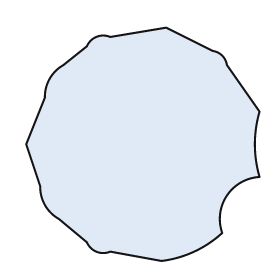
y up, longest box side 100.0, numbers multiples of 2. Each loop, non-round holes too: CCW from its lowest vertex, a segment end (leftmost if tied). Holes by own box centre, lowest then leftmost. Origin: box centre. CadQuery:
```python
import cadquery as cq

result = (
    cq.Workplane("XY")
    .moveTo(8.0, -50.0)
    .threePointArc((22.0, -46.0), (34.0, -38.0))
    .threePointArc((36.0, -22.0), (50.0, -14.0))
    .threePointArc((48.0, 0.0), (50.0, 14.0))
    .lineTo(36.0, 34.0)
    .threePointArc((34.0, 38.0), (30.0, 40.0))
    .lineTo(10.0, 50.0)
    .lineTo(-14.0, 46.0)
    .threePointArc((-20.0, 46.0), (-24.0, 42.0))
    .lineTo(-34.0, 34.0)
    .threePointArc((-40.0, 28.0), (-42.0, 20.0))
    .lineTo(-50.0, 0.0)
    .lineTo(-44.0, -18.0)
    .threePointArc((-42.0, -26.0), (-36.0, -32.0))
    .lineTo(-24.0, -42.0)
    .threePointArc((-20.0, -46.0), (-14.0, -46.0))
    .close()
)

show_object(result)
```